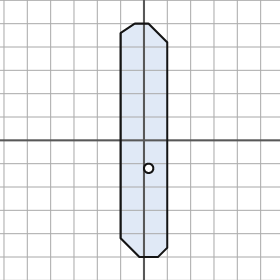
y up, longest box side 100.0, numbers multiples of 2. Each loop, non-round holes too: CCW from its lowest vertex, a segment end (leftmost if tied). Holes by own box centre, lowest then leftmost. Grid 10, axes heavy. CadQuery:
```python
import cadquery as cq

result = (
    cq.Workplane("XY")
    .moveTo(-2.0, -50.0)
    .lineTo(6.0, -50.0)
    .lineTo(10.0, -46.0)
    .lineTo(10.0, 42.0)
    .lineTo(2.0, 50.0)
    .lineTo(-4.0, 50.0)
    .lineTo(-10.0, 46.0)
    .lineTo(-10.0, -42.0)
    .close()
    .moveTo(2.0, -12.0)
    .circle(2.0)
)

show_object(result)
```